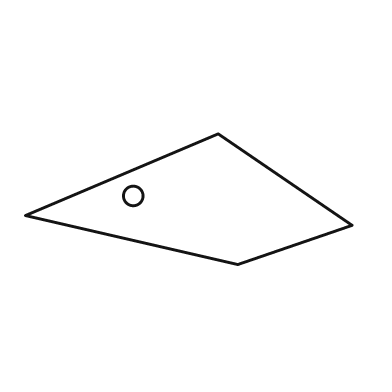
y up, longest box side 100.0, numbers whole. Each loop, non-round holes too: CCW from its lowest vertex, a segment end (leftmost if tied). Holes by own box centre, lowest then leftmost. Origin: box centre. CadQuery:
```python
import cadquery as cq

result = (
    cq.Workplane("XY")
    .moveTo(15.0, -20.0)
    .lineTo(50.0, -8.0)
    .lineTo(9.0, 20.0)
    .lineTo(-50.0, -5.0)
    .close()
    .moveTo(-17.0, 1.0)
    .circle(3.0)
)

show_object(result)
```